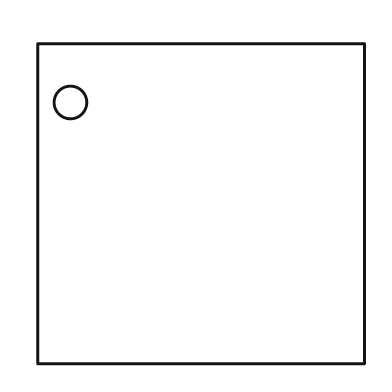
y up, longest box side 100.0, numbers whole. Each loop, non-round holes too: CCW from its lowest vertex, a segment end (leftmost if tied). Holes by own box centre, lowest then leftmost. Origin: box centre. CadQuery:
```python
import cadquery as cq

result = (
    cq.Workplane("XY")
    .moveTo(-50.0, -49.0)
    .lineTo(50.0, -49.0)
    .lineTo(50.0, 49.0)
    .lineTo(-50.0, 49.0)
    .close()
    .moveTo(-40.0, 31.0)
    .circle(5.0)
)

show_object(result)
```